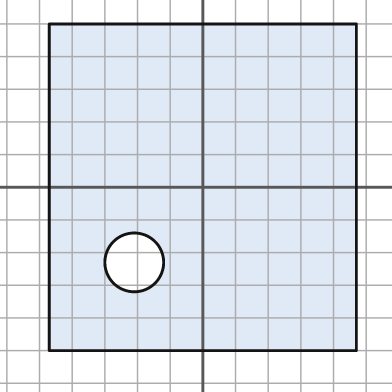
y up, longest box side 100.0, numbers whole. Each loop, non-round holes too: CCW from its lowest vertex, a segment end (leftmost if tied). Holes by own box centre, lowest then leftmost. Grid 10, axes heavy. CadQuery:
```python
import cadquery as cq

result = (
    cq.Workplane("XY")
    .moveTo(-47.0, -50.0)
    .lineTo(47.0, -50.0)
    .lineTo(47.0, 50.0)
    .lineTo(-47.0, 50.0)
    .close()
    .moveTo(-21.0, -23.0)
    .circle(9.0)
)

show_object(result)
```